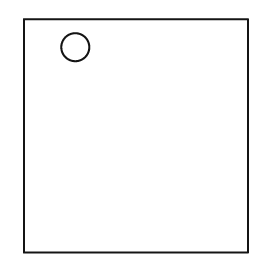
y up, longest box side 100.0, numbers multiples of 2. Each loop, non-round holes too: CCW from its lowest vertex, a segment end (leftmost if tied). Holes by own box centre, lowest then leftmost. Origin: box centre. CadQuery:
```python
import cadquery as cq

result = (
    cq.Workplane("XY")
    .moveTo(-48.0, -50.0)
    .lineTo(48.0, -50.0)
    .lineTo(48.0, 50.0)
    .lineTo(-48.0, 50.0)
    .close()
    .moveTo(-26.0, 38.0)
    .circle(6.0)
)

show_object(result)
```